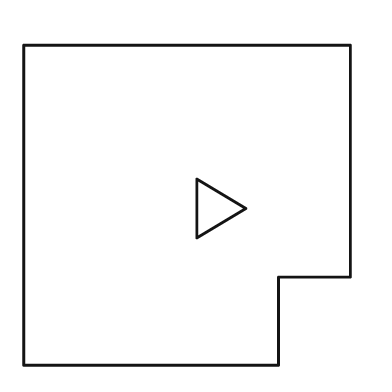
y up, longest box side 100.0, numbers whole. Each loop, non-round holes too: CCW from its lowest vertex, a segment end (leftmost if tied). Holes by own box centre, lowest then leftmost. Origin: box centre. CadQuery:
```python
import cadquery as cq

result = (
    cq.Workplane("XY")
    .moveTo(-50.0, -49.0)
    .lineTo(28.0, -49.0)
    .lineTo(28.0, -22.0)
    .lineTo(50.0, -22.0)
    .lineTo(50.0, 49.0)
    .lineTo(-50.0, 49.0)
    .close()
    .moveTo(3.0, -10.0)
    .lineTo(18.0, -1.0)
    .lineTo(3.0, 8.0)
    .close()
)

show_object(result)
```